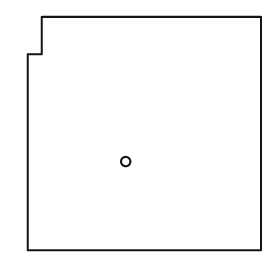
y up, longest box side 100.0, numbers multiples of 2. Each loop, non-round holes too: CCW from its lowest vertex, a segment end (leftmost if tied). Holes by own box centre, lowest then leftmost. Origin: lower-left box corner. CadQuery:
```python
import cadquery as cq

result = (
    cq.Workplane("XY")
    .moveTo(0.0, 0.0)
    .lineTo(100.0, 0.0)
    .lineTo(100.0, 100.0)
    .lineTo(6.0, 100.0)
    .lineTo(6.0, 84.0)
    .lineTo(0.0, 84.0)
    .close()
    .moveTo(42.0, 38.0)
    .circle(2.0)
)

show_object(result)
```